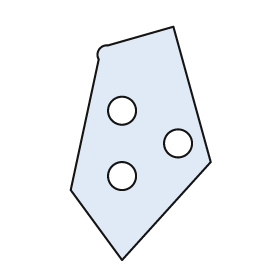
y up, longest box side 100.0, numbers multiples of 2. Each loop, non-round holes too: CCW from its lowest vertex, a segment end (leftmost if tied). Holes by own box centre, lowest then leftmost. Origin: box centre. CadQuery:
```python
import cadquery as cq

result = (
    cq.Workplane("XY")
    .moveTo(-8.0, -50.0)
    .lineTo(30.0, -8.0)
    .lineTo(14.0, 50.0)
    .lineTo(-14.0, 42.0)
    .threePointArc((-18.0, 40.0), (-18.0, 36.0))
    .lineTo(-30.0, -20.0)
    .close()
    .moveTo(-8.0, -14.0)
    .circle(6.0)
    .moveTo(16.0, 0.0)
    .circle(6.0)
    .moveTo(-8.0, 14.0)
    .circle(6.0)
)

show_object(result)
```